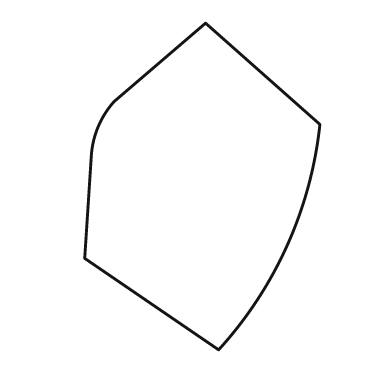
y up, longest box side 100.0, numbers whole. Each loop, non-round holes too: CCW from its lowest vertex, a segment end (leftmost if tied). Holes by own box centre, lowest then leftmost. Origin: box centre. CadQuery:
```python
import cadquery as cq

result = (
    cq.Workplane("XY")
    .moveTo(5.0, -50.0)
    .threePointArc((26.0, -18.0), (36.0, 19.0))
    .lineTo(1.0, 50.0)
    .lineTo(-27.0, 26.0)
    .threePointArc((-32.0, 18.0), (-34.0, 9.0))
    .lineTo(-36.0, -22.0)
    .close()
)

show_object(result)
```